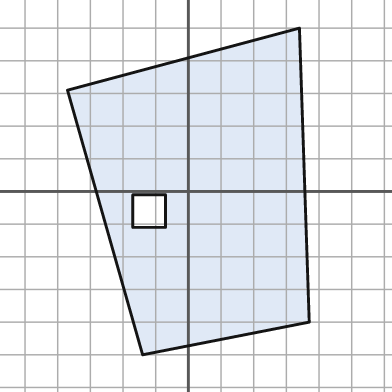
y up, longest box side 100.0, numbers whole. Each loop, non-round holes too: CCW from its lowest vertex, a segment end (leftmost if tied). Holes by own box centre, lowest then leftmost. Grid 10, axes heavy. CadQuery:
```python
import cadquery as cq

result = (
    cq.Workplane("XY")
    .moveTo(-14.0, -50.0)
    .lineTo(37.0, -40.0)
    .lineTo(34.0, 50.0)
    .lineTo(-37.0, 31.0)
    .close()
    .moveTo(-17.0, -11.0)
    .lineTo(-7.0, -11.0)
    .lineTo(-7.0, -1.0)
    .lineTo(-17.0, -1.0)
    .close()
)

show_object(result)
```